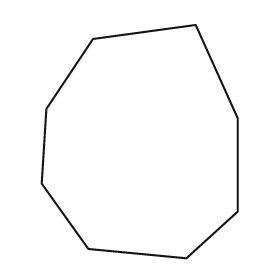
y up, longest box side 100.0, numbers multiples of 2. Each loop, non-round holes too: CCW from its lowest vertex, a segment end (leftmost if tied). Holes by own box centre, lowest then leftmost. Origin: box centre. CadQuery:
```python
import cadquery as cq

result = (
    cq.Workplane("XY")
    .moveTo(20.0, -50.0)
    .lineTo(42.0, -30.0)
    .lineTo(42.0, 10.0)
    .lineTo(24.0, 50.0)
    .lineTo(-20.0, 44.0)
    .lineTo(-40.0, 14.0)
    .lineTo(-42.0, -18.0)
    .lineTo(-22.0, -46.0)
    .close()
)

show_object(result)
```